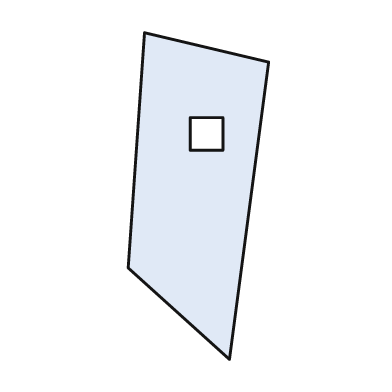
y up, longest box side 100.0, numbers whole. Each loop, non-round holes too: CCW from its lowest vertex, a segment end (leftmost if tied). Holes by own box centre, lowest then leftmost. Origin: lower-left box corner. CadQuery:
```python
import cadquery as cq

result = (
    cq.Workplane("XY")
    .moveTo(31.0, 0.0)
    .lineTo(43.0, 91.0)
    .lineTo(5.0, 100.0)
    .lineTo(0.0, 28.0)
    .close()
    .moveTo(19.0, 64.0)
    .lineTo(29.0, 64.0)
    .lineTo(29.0, 74.0)
    .lineTo(19.0, 74.0)
    .close()
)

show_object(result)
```